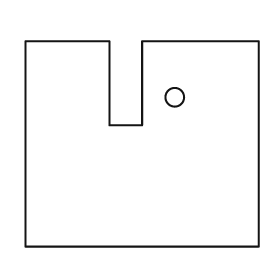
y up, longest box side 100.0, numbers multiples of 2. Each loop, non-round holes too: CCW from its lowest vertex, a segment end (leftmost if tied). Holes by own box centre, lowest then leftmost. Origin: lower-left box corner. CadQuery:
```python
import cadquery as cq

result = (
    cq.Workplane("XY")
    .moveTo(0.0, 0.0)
    .lineTo(100.0, 0.0)
    .lineTo(100.0, 88.0)
    .lineTo(50.0, 88.0)
    .lineTo(50.0, 52.0)
    .lineTo(36.0, 52.0)
    .lineTo(36.0, 88.0)
    .lineTo(0.0, 88.0)
    .close()
    .moveTo(64.0, 64.0)
    .circle(4.0)
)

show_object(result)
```